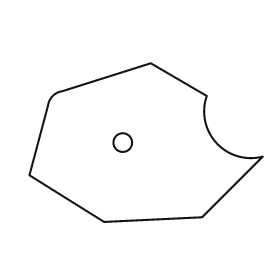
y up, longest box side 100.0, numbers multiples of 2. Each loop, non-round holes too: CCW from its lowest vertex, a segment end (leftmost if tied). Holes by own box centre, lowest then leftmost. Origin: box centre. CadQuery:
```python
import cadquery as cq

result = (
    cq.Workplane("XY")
    .moveTo(-18.0, -34.0)
    .lineTo(24.0, -32.0)
    .lineTo(50.0, -6.0)
    .threePointArc((30.0, 0.0), (26.0, 20.0))
    .lineTo(2.0, 34.0)
    .lineTo(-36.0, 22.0)
    .threePointArc((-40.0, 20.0), (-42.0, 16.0))
    .lineTo(-50.0, -14.0)
    .close()
    .moveTo(-10.0, 0.0)
    .circle(4.0)
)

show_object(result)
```